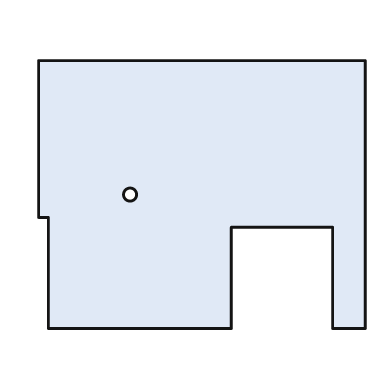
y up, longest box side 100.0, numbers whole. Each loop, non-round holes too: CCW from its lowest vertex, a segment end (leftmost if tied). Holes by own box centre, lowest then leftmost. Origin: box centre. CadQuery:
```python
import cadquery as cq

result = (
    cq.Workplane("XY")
    .moveTo(-47.0, -41.0)
    .lineTo(9.0, -41.0)
    .lineTo(9.0, -10.0)
    .lineTo(40.0, -10.0)
    .lineTo(40.0, -41.0)
    .lineTo(50.0, -41.0)
    .lineTo(50.0, 41.0)
    .lineTo(-50.0, 41.0)
    .lineTo(-50.0, -7.0)
    .lineTo(-47.0, -7.0)
    .close()
    .moveTo(-22.0, 0.0)
    .circle(2.0)
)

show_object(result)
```